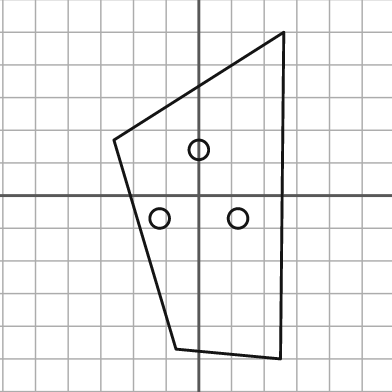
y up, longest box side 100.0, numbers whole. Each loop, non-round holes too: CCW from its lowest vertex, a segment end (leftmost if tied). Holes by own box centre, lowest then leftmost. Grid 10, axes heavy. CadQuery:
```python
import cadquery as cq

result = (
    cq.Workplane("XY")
    .moveTo(25.0, -50.0)
    .lineTo(26.0, 50.0)
    .lineTo(-26.0, 17.0)
    .lineTo(-7.0, -47.0)
    .close()
    .moveTo(-12.0, -7.0)
    .circle(3.0)
    .moveTo(12.0, -7.0)
    .circle(3.0)
    .moveTo(0.0, 14.0)
    .circle(3.0)
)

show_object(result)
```